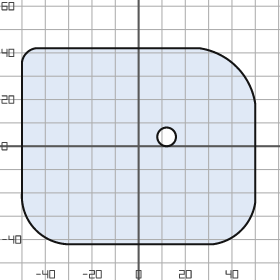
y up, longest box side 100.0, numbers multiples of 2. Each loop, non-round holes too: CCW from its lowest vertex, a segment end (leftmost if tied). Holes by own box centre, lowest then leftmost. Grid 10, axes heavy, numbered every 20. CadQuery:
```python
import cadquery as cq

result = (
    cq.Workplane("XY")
    .moveTo(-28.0, -42.0)
    .lineTo(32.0, -42.0)
    .threePointArc((44.0, -36.0), (50.0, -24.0))
    .lineTo(50.0, 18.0)
    .threePointArc((42.0, 34.0), (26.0, 42.0))
    .lineTo(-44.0, 42.0)
    .threePointArc((-48.0, 40.0), (-50.0, 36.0))
    .lineTo(-50.0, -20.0)
    .threePointArc((-44.0, -36.0), (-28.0, -42.0))
    .close()
    .moveTo(12.0, 4.0)
    .circle(4.0)
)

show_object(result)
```